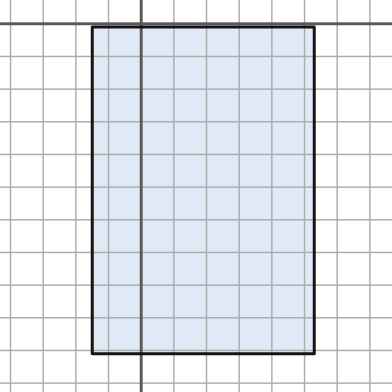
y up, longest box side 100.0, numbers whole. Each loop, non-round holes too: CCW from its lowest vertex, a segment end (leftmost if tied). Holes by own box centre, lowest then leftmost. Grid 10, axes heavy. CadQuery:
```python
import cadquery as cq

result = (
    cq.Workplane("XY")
    .moveTo(-15.0, -101.0)
    .lineTo(53.0, -101.0)
    .lineTo(53.0, -1.0)
    .lineTo(-15.0, -1.0)
    .close()
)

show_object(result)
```